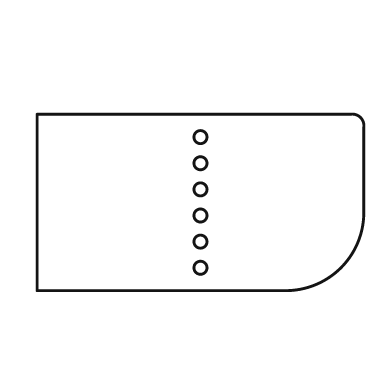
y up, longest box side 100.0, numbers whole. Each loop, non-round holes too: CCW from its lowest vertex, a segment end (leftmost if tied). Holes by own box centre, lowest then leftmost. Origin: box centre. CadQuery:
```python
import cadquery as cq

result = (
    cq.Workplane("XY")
    .moveTo(-50.0, -27.0)
    .lineTo(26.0, -27.0)
    .threePointArc((43.0, -20.0), (50.0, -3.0))
    .lineTo(50.0, 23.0)
    .threePointArc((49.0, 26.0), (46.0, 27.0))
    .lineTo(-50.0, 27.0)
    .close()
    .moveTo(0.0, -20.0)
    .circle(2.0)
    .moveTo(0.0, -12.0)
    .circle(2.0)
    .moveTo(0.0, -4.0)
    .circle(2.0)
    .moveTo(0.0, 4.0)
    .circle(2.0)
    .moveTo(0.0, 12.0)
    .circle(2.0)
    .moveTo(0.0, 20.0)
    .circle(2.0)
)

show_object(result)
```